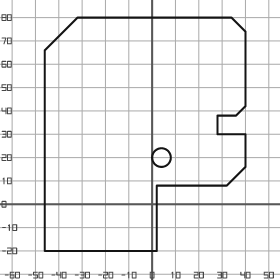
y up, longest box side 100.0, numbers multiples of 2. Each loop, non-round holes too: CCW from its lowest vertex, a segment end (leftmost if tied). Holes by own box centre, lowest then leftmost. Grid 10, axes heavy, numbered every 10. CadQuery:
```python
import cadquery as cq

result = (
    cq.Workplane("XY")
    .moveTo(-46.0, -20.0)
    .lineTo(2.0, -20.0)
    .lineTo(2.0, 8.0)
    .lineTo(32.0, 8.0)
    .lineTo(40.0, 16.0)
    .lineTo(40.0, 30.0)
    .lineTo(28.0, 30.0)
    .lineTo(28.0, 38.0)
    .lineTo(36.0, 38.0)
    .lineTo(40.0, 42.0)
    .lineTo(40.0, 74.0)
    .lineTo(34.0, 80.0)
    .lineTo(-32.0, 80.0)
    .lineTo(-46.0, 66.0)
    .close()
    .moveTo(4.0, 20.0)
    .circle(4.0)
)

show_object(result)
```